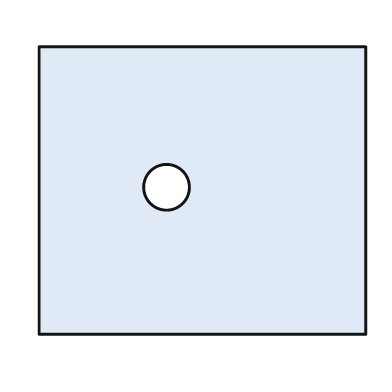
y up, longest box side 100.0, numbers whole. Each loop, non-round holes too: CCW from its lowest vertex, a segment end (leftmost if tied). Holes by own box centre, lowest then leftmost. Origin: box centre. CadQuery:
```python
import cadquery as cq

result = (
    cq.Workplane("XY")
    .moveTo(-50.0, -44.0)
    .lineTo(50.0, -44.0)
    .lineTo(50.0, 44.0)
    .lineTo(-50.0, 44.0)
    .close()
    .moveTo(-11.0, 1.0)
    .circle(7.0)
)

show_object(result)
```